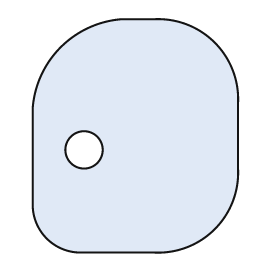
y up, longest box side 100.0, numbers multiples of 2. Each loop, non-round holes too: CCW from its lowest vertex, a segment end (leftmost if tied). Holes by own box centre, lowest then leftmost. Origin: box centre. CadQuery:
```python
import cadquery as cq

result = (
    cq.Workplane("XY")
    .moveTo(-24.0, -50.0)
    .lineTo(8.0, -50.0)
    .threePointArc((34.0, -40.0), (44.0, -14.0))
    .lineTo(44.0, 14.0)
    .threePointArc((34.0, 40.0), (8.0, 50.0))
    .lineTo(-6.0, 50.0)
    .threePointArc((-32.0, 38.0), (-44.0, 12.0))
    .lineTo(-44.0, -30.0)
    .threePointArc((-38.0, -44.0), (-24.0, -50.0))
    .close()
    .moveTo(-22.0, -6.0)
    .circle(8.0)
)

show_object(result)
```